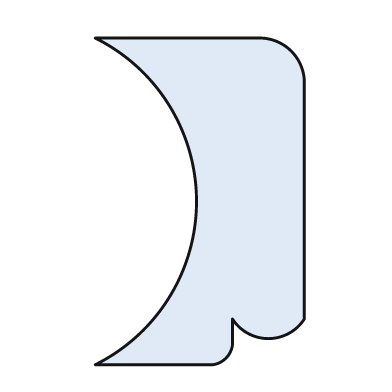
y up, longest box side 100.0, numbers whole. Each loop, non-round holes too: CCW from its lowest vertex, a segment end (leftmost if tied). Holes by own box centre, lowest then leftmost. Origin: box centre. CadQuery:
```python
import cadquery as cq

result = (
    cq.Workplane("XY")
    .moveTo(-32.0, -50.0)
    .lineTo(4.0, -50.0)
    .threePointArc((8.0, -48.0), (10.0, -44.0))
    .lineTo(10.0, -36.0)
    .threePointArc((21.0, -42.0), (32.0, -36.0))
    .lineTo(32.0, 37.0)
    .threePointArc((28.0, 46.0), (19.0, 50.0))
    .lineTo(-32.0, 50.0)
    .threePointArc((-1.0, 0.0), (-32.0, -50.0))
    .close()
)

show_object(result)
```